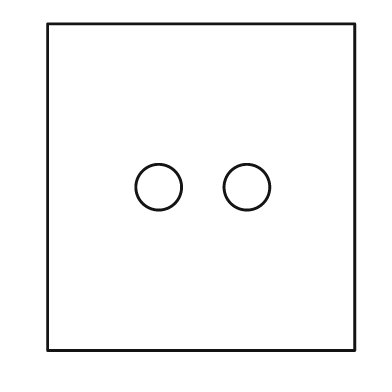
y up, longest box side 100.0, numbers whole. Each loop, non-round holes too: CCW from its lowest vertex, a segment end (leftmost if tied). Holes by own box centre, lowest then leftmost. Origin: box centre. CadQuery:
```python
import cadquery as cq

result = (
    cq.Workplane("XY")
    .moveTo(-47.0, -50.0)
    .lineTo(47.0, -50.0)
    .lineTo(47.0, 50.0)
    .lineTo(-47.0, 50.0)
    .close()
    .moveTo(-13.0, 0.0)
    .circle(7.0)
    .moveTo(14.0, 0.0)
    .circle(7.0)
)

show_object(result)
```